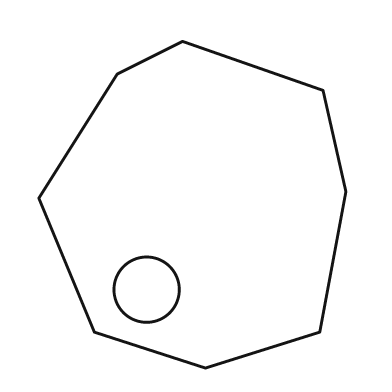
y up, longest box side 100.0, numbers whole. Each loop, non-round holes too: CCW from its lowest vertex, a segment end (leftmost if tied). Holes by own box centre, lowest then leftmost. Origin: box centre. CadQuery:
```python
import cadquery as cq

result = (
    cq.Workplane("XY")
    .moveTo(4.0, -50.0)
    .lineTo(39.0, -39.0)
    .lineTo(47.0, 4.0)
    .lineTo(40.0, 35.0)
    .lineTo(-3.0, 50.0)
    .lineTo(-23.0, 40.0)
    .lineTo(-47.0, 2.0)
    .lineTo(-30.0, -39.0)
    .close()
    .moveTo(-14.0, -26.0)
    .circle(10.0)
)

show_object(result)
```